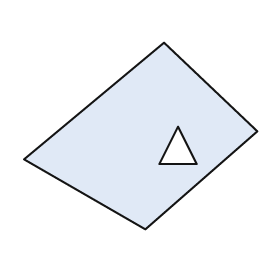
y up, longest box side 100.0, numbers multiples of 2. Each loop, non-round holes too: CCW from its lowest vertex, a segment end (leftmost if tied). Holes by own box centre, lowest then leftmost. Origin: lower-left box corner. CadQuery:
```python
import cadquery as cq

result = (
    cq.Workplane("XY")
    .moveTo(52.0, 0.0)
    .lineTo(100.0, 42.0)
    .lineTo(60.0, 80.0)
    .lineTo(0.0, 30.0)
    .close()
    .moveTo(58.0, 28.0)
    .lineTo(74.0, 28.0)
    .lineTo(66.0, 44.0)
    .close()
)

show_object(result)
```